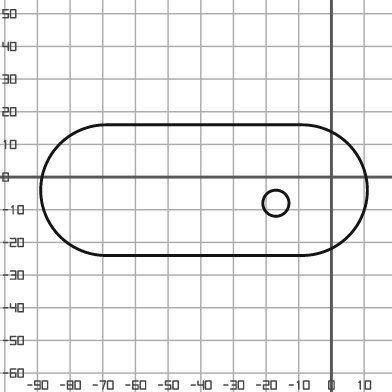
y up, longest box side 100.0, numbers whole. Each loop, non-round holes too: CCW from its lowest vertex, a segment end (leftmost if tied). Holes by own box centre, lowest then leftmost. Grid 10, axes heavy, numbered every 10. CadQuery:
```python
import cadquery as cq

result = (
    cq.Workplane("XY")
    .moveTo(-69.0, -24.0)
    .lineTo(-9.0, -24.0)
    .threePointArc((11.0, -4.0), (-9.0, 16.0))
    .lineTo(-69.0, 16.0)
    .threePointArc((-89.0, -4.0), (-69.0, -24.0))
    .close()
    .moveTo(-17.0, -8.0)
    .circle(4.0)
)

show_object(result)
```